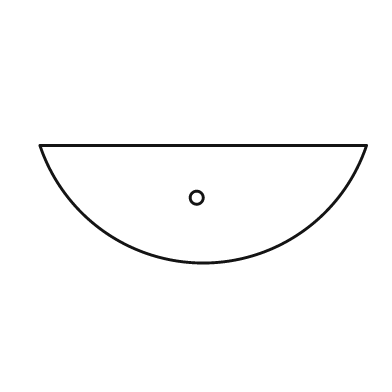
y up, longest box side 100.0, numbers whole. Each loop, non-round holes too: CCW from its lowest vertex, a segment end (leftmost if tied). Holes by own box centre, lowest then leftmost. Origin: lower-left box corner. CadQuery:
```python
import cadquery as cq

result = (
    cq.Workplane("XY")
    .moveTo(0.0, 36.0)
    .threePointArc((50.0, 0.0), (100.0, 36.0))
    .close()
    .moveTo(48.0, 20.0)
    .circle(2.0)
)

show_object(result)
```